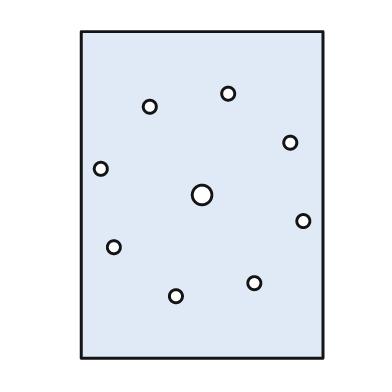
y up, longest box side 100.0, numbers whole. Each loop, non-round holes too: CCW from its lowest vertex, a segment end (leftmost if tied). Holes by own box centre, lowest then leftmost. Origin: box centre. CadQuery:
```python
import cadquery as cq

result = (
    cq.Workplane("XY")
    .moveTo(-37.0, -50.0)
    .lineTo(37.0, -50.0)
    .lineTo(37.0, 50.0)
    .lineTo(-37.0, 50.0)
    .close()
    .moveTo(-8.0, -31.0)
    .circle(2.0)
    .moveTo(16.0, -27.0)
    .circle(2.0)
    .moveTo(-27.0, -16.0)
    .circle(2.0)
    .moveTo(31.0, -8.0)
    .circle(2.0)
    .moveTo(0.0, 0.0)
    .circle(3.0)
    .moveTo(-31.0, 8.0)
    .circle(2.0)
    .moveTo(27.0, 16.0)
    .circle(2.0)
    .moveTo(-16.0, 27.0)
    .circle(2.0)
    .moveTo(8.0, 31.0)
    .circle(2.0)
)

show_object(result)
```